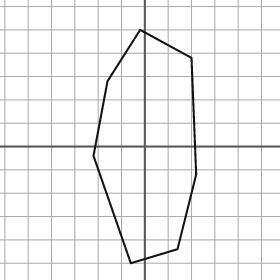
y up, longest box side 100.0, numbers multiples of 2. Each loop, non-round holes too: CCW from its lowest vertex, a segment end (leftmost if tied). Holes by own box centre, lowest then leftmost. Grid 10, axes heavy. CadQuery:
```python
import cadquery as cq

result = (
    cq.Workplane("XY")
    .moveTo(-6.0, -50.0)
    .lineTo(14.0, -44.0)
    .lineTo(22.0, -12.0)
    .lineTo(20.0, 38.0)
    .lineTo(-2.0, 50.0)
    .lineTo(-16.0, 28.0)
    .lineTo(-22.0, -4.0)
    .close()
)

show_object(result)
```